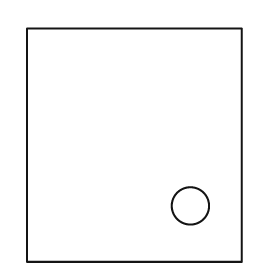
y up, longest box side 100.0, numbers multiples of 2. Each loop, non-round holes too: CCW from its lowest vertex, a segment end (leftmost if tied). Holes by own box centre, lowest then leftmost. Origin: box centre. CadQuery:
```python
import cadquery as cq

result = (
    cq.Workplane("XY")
    .moveTo(-46.0, -50.0)
    .lineTo(46.0, -50.0)
    .lineTo(46.0, 50.0)
    .lineTo(-46.0, 50.0)
    .close()
    .moveTo(24.0, -26.0)
    .circle(8.0)
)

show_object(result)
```